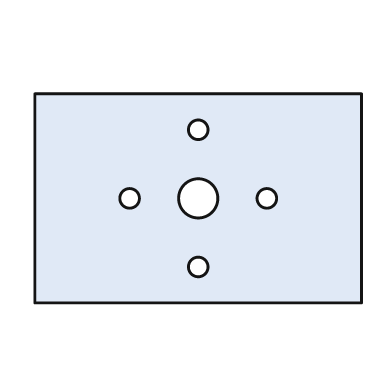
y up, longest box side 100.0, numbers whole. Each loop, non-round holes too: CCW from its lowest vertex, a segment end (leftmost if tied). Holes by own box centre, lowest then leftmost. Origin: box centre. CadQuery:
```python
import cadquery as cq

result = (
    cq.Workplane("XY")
    .moveTo(-50.0, -32.0)
    .lineTo(50.0, -32.0)
    .lineTo(50.0, 32.0)
    .lineTo(-50.0, 32.0)
    .close()
    .moveTo(0.0, -21.0)
    .circle(3.0)
    .moveTo(-21.0, 0.0)
    .circle(3.0)
    .moveTo(0.0, 0.0)
    .circle(6.0)
    .moveTo(21.0, 0.0)
    .circle(3.0)
    .moveTo(0.0, 21.0)
    .circle(3.0)
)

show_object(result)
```